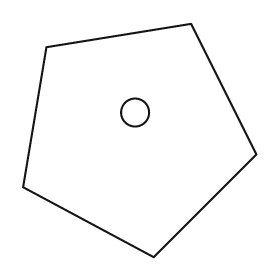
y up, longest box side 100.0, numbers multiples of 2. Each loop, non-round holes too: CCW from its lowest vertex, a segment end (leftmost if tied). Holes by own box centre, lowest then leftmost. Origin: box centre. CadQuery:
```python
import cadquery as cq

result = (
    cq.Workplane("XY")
    .moveTo(6.0, -50.0)
    .lineTo(50.0, -6.0)
    .lineTo(22.0, 50.0)
    .lineTo(-40.0, 40.0)
    .lineTo(-50.0, -20.0)
    .close()
    .moveTo(-2.0, 12.0)
    .circle(6.0)
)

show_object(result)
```